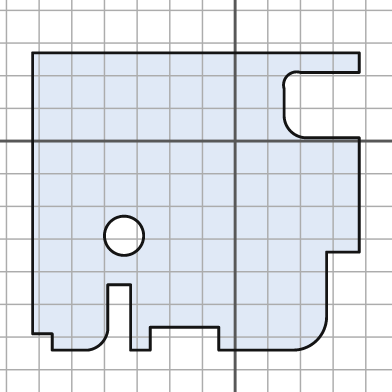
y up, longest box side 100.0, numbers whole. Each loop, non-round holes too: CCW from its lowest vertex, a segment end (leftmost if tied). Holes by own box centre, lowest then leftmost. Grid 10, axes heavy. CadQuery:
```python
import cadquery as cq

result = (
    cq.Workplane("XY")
    .moveTo(-56.0, -64.0)
    .lineTo(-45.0, -64.0)
    .threePointArc((-41.0, -62.0), (-39.0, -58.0))
    .lineTo(-39.0, -44.0)
    .lineTo(-32.0, -44.0)
    .lineTo(-32.0, -64.0)
    .lineTo(-26.0, -64.0)
    .lineTo(-26.0, -57.0)
    .lineTo(-5.0, -57.0)
    .lineTo(-5.0, -64.0)
    .lineTo(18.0, -64.0)
    .threePointArc((25.0, -61.0), (28.0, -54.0))
    .lineTo(28.0, -34.0)
    .lineTo(38.0, -34.0)
    .lineTo(38.0, 1.0)
    .lineTo(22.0, 1.0)
    .threePointArc((17.0, 3.0), (15.0, 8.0))
    .lineTo(15.0, 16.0)
    .threePointArc((16.0, 20.0), (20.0, 21.0))
    .lineTo(38.0, 21.0)
    .lineTo(38.0, 27.0)
    .lineTo(-62.0, 27.0)
    .lineTo(-62.0, -59.0)
    .lineTo(-56.0, -59.0)
    .close()
    .moveTo(-34.0, -29.0)
    .circle(6.0)
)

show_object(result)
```